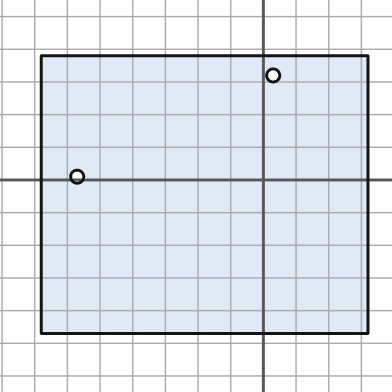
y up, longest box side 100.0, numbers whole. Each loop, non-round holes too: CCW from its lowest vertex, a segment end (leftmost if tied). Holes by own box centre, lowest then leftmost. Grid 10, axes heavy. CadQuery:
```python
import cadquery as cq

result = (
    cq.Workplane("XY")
    .moveTo(-68.0, -47.0)
    .lineTo(32.0, -47.0)
    .lineTo(32.0, 38.0)
    .lineTo(-68.0, 38.0)
    .close()
    .moveTo(-57.0, 1.0)
    .circle(2.0)
    .moveTo(3.0, 32.0)
    .circle(2.0)
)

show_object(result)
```